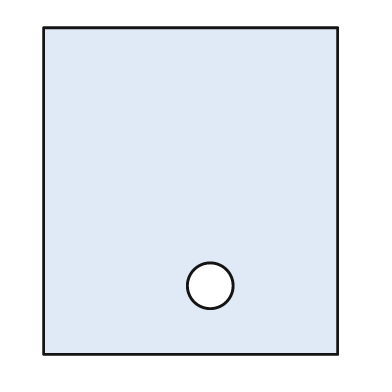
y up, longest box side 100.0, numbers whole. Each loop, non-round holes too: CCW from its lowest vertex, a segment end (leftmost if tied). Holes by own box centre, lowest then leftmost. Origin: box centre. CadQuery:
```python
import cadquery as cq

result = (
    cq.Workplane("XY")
    .moveTo(-45.0, -50.0)
    .lineTo(45.0, -50.0)
    .lineTo(45.0, 50.0)
    .lineTo(-45.0, 50.0)
    .close()
    .moveTo(6.0, -29.0)
    .circle(7.0)
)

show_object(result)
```